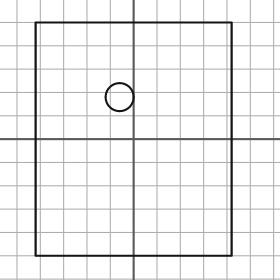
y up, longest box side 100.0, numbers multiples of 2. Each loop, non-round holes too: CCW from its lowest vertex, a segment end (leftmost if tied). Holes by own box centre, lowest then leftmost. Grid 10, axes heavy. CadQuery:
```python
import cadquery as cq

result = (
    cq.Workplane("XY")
    .moveTo(-42.0, -50.0)
    .lineTo(42.0, -50.0)
    .lineTo(42.0, 50.0)
    .lineTo(-42.0, 50.0)
    .close()
    .moveTo(-6.0, 18.0)
    .circle(6.0)
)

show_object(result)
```